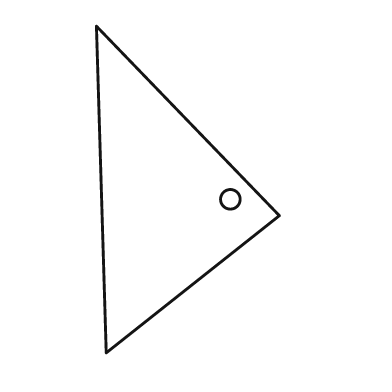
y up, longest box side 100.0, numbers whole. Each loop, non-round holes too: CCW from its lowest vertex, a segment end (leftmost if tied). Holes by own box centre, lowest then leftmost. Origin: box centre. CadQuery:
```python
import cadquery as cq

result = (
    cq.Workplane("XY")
    .moveTo(-25.0, -50.0)
    .lineTo(28.0, -8.0)
    .lineTo(-28.0, 50.0)
    .close()
    .moveTo(13.0, -3.0)
    .circle(3.0)
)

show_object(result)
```